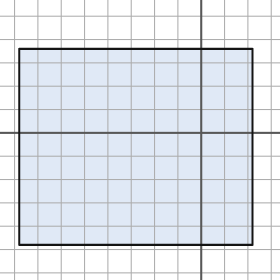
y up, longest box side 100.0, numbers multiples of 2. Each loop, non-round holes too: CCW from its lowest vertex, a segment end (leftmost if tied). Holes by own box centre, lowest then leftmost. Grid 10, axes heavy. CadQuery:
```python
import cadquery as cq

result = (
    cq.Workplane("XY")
    .moveTo(-78.0, -48.0)
    .lineTo(22.0, -48.0)
    .lineTo(22.0, 36.0)
    .lineTo(-78.0, 36.0)
    .close()
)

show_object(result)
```